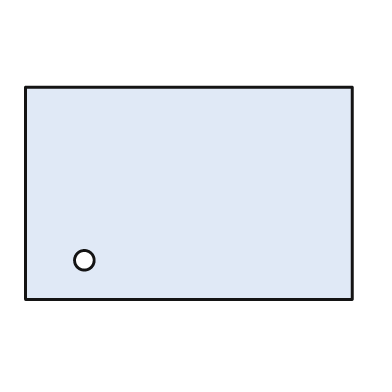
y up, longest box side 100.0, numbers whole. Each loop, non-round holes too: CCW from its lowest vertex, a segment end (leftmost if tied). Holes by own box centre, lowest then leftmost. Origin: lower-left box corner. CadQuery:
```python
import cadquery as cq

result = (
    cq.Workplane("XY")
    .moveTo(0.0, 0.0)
    .lineTo(100.0, 0.0)
    .lineTo(100.0, 65.0)
    .lineTo(0.0, 65.0)
    .close()
    .moveTo(18.0, 12.0)
    .circle(3.0)
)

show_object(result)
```